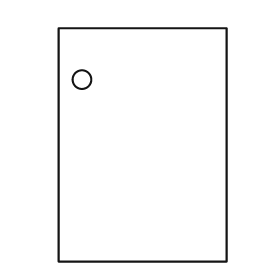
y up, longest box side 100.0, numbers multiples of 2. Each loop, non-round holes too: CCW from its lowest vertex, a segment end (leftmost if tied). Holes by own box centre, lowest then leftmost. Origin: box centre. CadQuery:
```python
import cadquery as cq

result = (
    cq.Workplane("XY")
    .moveTo(-36.0, -50.0)
    .lineTo(36.0, -50.0)
    .lineTo(36.0, 50.0)
    .lineTo(-36.0, 50.0)
    .close()
    .moveTo(-26.0, 28.0)
    .circle(4.0)
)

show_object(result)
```